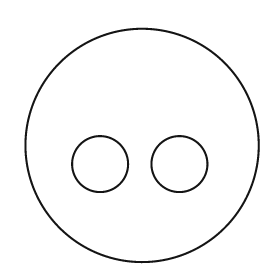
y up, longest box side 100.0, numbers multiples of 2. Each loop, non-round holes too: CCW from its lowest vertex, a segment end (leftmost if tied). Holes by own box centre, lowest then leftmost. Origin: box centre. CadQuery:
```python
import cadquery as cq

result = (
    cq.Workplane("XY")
    .moveTo(0.0, 0.0)
    .circle(50.0)
    .moveTo(-18.0, -8.0)
    .circle(12.0)
    .moveTo(16.0, -8.0)
    .circle(12.0)
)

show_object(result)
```